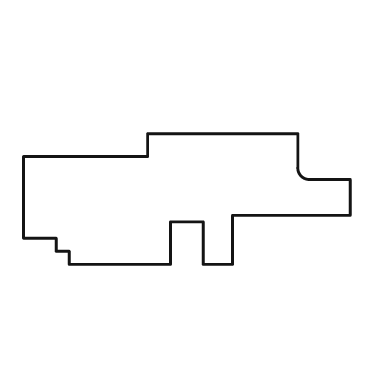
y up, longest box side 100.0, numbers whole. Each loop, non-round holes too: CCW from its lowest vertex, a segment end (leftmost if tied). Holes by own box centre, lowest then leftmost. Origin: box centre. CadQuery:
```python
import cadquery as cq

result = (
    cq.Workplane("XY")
    .moveTo(-36.0, -20.0)
    .lineTo(-5.0, -20.0)
    .lineTo(-5.0, -7.0)
    .lineTo(5.0, -7.0)
    .lineTo(5.0, -20.0)
    .lineTo(14.0, -20.0)
    .lineTo(14.0, -5.0)
    .lineTo(50.0, -5.0)
    .lineTo(50.0, 6.0)
    .lineTo(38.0, 6.0)
    .threePointArc((35.0, 7.0), (34.0, 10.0))
    .lineTo(34.0, 20.0)
    .lineTo(-12.0, 20.0)
    .lineTo(-12.0, 13.0)
    .lineTo(-50.0, 13.0)
    .lineTo(-50.0, -12.0)
    .lineTo(-40.0, -12.0)
    .lineTo(-40.0, -16.0)
    .lineTo(-36.0, -16.0)
    .close()
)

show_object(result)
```